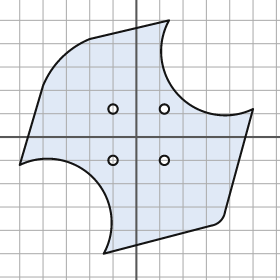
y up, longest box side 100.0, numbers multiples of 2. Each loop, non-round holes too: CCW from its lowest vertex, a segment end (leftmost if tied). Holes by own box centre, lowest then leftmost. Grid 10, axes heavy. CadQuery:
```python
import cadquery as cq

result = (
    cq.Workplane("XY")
    .moveTo(-14.0, -50.0)
    .lineTo(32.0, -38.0)
    .threePointArc((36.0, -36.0), (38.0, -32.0))
    .lineTo(50.0, 12.0)
    .threePointArc((18.0, 18.0), (14.0, 50.0))
    .lineTo(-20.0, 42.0)
    .threePointArc((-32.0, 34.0), (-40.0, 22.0))
    .lineTo(-50.0, -12.0)
    .threePointArc((-18.0, -18.0), (-14.0, -50.0))
    .close()
    .moveTo(-10.0, -10.0)
    .circle(2.0)
    .moveTo(12.0, -10.0)
    .circle(2.0)
    .moveTo(-10.0, 12.0)
    .circle(2.0)
    .moveTo(12.0, 12.0)
    .circle(2.0)
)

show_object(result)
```